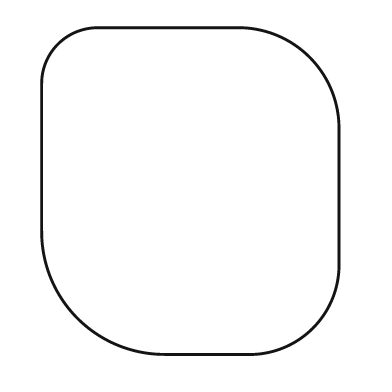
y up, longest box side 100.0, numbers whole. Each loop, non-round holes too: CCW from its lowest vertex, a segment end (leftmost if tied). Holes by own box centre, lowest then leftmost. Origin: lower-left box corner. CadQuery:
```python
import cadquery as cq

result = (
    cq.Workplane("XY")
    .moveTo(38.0, 0.0)
    .lineTo(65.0, 0.0)
    .threePointArc((83.0, 8.0), (91.0, 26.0))
    .lineTo(91.0, 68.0)
    .threePointArc((82.0, 91.0), (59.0, 100.0))
    .lineTo(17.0, 100.0)
    .threePointArc((5.0, 95.0), (0.0, 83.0))
    .lineTo(0.0, 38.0)
    .threePointArc((11.0, 11.0), (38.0, 0.0))
    .close()
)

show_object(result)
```